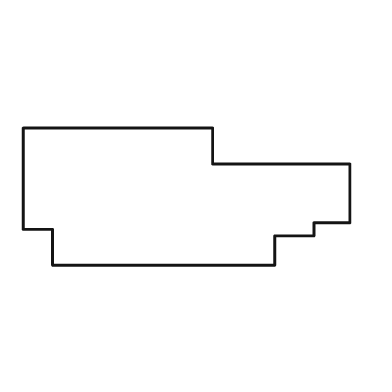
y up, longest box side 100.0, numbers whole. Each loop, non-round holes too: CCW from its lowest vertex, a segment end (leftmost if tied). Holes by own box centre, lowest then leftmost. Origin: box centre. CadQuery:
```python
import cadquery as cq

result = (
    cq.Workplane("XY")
    .moveTo(-41.0, -21.0)
    .lineTo(27.0, -21.0)
    .lineTo(27.0, -12.0)
    .lineTo(39.0, -12.0)
    .lineTo(39.0, -8.0)
    .lineTo(50.0, -8.0)
    .lineTo(50.0, 10.0)
    .lineTo(8.0, 10.0)
    .lineTo(8.0, 21.0)
    .lineTo(-50.0, 21.0)
    .lineTo(-50.0, -10.0)
    .lineTo(-41.0, -10.0)
    .close()
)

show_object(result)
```